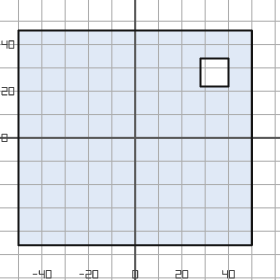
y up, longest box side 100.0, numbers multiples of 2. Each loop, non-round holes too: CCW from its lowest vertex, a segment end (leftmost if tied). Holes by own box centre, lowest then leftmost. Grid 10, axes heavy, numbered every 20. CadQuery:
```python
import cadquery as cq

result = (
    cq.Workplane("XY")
    .moveTo(-50.0, -46.0)
    .lineTo(50.0, -46.0)
    .lineTo(50.0, 46.0)
    .lineTo(-50.0, 46.0)
    .close()
    .moveTo(28.0, 22.0)
    .lineTo(40.0, 22.0)
    .lineTo(40.0, 34.0)
    .lineTo(28.0, 34.0)
    .close()
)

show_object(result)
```